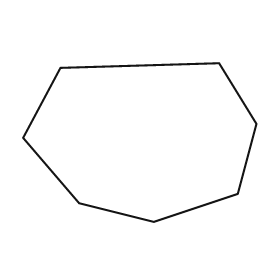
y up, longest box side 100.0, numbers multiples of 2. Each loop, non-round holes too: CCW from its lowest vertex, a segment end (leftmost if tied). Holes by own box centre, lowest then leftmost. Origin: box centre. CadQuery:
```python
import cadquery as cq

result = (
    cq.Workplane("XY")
    .moveTo(6.0, -34.0)
    .lineTo(42.0, -22.0)
    .lineTo(50.0, 8.0)
    .lineTo(34.0, 34.0)
    .lineTo(-34.0, 32.0)
    .lineTo(-50.0, 2.0)
    .lineTo(-26.0, -26.0)
    .close()
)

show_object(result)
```